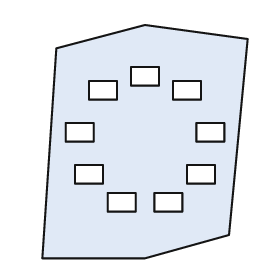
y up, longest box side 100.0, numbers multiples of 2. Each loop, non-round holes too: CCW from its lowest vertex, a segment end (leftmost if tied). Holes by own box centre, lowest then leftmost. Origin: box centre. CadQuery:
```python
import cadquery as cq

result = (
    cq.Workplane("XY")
    .moveTo(-44.0, -50.0)
    .lineTo(0.0, -50.0)
    .lineTo(36.0, -40.0)
    .lineTo(44.0, 44.0)
    .lineTo(0.0, 50.0)
    .lineTo(-38.0, 40.0)
    .close()
    .moveTo(-16.0, -30.0)
    .lineTo(-4.0, -30.0)
    .lineTo(-4.0, -22.0)
    .lineTo(-16.0, -22.0)
    .close()
    .moveTo(4.0, -30.0)
    .lineTo(16.0, -30.0)
    .lineTo(16.0, -22.0)
    .lineTo(4.0, -22.0)
    .close()
    .moveTo(-30.0, -18.0)
    .lineTo(-18.0, -18.0)
    .lineTo(-18.0, -10.0)
    .lineTo(-30.0, -10.0)
    .close()
    .moveTo(18.0, -18.0)
    .lineTo(30.0, -18.0)
    .lineTo(30.0, -10.0)
    .lineTo(18.0, -10.0)
    .close()
    .moveTo(-34.0, 0.0)
    .lineTo(-22.0, 0.0)
    .lineTo(-22.0, 8.0)
    .lineTo(-34.0, 8.0)
    .close()
    .moveTo(22.0, 0.0)
    .lineTo(34.0, 0.0)
    .lineTo(34.0, 8.0)
    .lineTo(22.0, 8.0)
    .close()
    .moveTo(-24.0, 18.0)
    .lineTo(-12.0, 18.0)
    .lineTo(-12.0, 26.0)
    .lineTo(-24.0, 26.0)
    .close()
    .moveTo(12.0, 18.0)
    .lineTo(24.0, 18.0)
    .lineTo(24.0, 26.0)
    .lineTo(12.0, 26.0)
    .close()
    .moveTo(-6.0, 24.0)
    .lineTo(6.0, 24.0)
    .lineTo(6.0, 32.0)
    .lineTo(-6.0, 32.0)
    .close()
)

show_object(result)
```